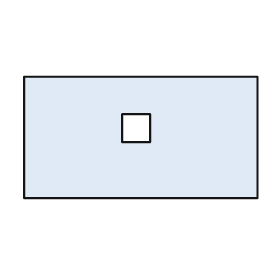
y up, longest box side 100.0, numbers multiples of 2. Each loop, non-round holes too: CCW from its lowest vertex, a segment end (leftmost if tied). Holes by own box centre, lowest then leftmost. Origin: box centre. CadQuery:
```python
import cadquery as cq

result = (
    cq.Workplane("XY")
    .moveTo(-50.0, -26.0)
    .lineTo(50.0, -26.0)
    .lineTo(50.0, 26.0)
    .lineTo(-50.0, 26.0)
    .close()
    .moveTo(-8.0, -2.0)
    .lineTo(4.0, -2.0)
    .lineTo(4.0, 10.0)
    .lineTo(-8.0, 10.0)
    .close()
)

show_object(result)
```